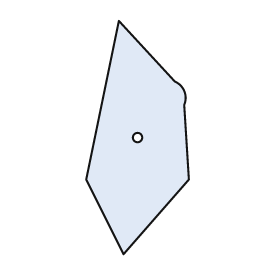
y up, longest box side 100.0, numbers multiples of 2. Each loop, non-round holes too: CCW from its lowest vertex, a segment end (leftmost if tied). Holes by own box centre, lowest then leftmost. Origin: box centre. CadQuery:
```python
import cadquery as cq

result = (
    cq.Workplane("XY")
    .moveTo(-6.0, -50.0)
    .lineTo(22.0, -18.0)
    .lineTo(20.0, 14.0)
    .threePointArc((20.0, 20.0), (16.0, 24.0))
    .lineTo(-8.0, 50.0)
    .lineTo(-22.0, -18.0)
    .close()
    .moveTo(0.0, 0.0)
    .circle(2.0)
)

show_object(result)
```